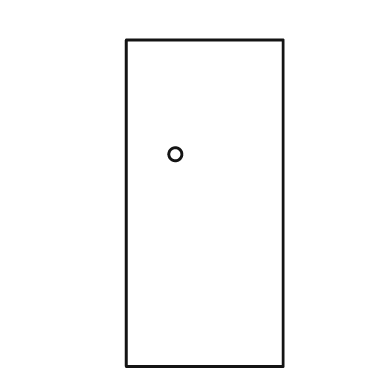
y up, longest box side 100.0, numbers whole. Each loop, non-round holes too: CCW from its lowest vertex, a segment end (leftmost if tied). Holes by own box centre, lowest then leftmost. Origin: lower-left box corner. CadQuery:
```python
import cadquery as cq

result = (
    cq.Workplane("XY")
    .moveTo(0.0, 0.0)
    .lineTo(48.0, 0.0)
    .lineTo(48.0, 100.0)
    .lineTo(0.0, 100.0)
    .close()
    .moveTo(15.0, 65.0)
    .circle(2.0)
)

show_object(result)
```